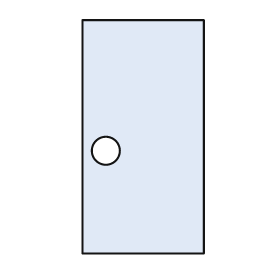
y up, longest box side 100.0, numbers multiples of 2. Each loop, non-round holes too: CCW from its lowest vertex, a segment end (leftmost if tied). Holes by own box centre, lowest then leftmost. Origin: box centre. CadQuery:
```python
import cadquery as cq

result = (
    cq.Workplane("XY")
    .moveTo(-26.0, -50.0)
    .lineTo(26.0, -50.0)
    .lineTo(26.0, 50.0)
    .lineTo(-26.0, 50.0)
    .close()
    .moveTo(-16.0, -6.0)
    .circle(6.0)
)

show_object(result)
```